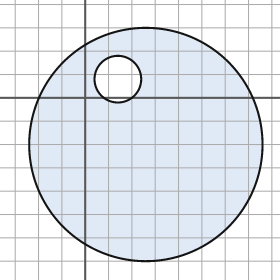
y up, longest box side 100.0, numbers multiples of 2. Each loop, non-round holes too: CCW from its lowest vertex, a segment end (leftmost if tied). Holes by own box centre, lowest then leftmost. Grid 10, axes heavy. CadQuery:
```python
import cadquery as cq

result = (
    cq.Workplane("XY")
    .moveTo(26.0, -20.0)
    .circle(50.0)
    .moveTo(14.0, 8.0)
    .circle(10.0)
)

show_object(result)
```